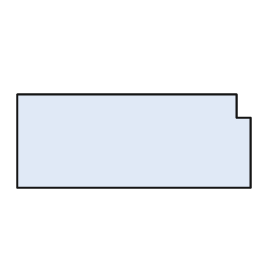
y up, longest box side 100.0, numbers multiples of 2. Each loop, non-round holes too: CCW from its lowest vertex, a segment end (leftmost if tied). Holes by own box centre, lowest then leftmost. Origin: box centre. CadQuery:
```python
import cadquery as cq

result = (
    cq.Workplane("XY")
    .moveTo(-50.0, -20.0)
    .lineTo(50.0, -20.0)
    .lineTo(50.0, 10.0)
    .lineTo(44.0, 10.0)
    .lineTo(44.0, 20.0)
    .lineTo(-50.0, 20.0)
    .close()
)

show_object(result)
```